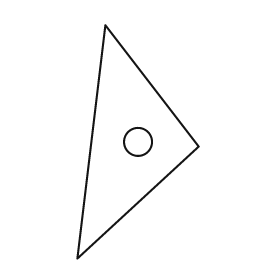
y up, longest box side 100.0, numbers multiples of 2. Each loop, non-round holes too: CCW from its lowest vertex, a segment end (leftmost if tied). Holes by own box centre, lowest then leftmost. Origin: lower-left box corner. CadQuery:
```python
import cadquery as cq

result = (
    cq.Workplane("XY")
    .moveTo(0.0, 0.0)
    .lineTo(52.0, 48.0)
    .lineTo(12.0, 100.0)
    .close()
    .moveTo(26.0, 50.0)
    .circle(6.0)
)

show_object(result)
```